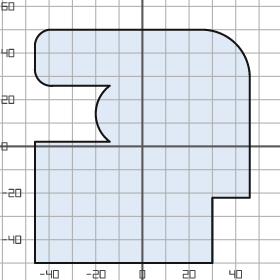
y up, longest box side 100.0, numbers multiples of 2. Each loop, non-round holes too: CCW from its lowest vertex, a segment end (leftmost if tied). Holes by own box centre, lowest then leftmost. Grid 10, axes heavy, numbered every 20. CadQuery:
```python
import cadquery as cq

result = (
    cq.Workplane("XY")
    .moveTo(-46.0, -50.0)
    .lineTo(30.0, -50.0)
    .lineTo(30.0, -22.0)
    .lineTo(46.0, -22.0)
    .lineTo(46.0, 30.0)
    .threePointArc((40.0, 44.0), (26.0, 50.0))
    .lineTo(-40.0, 50.0)
    .threePointArc((-44.0, 48.0), (-46.0, 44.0))
    .lineTo(-46.0, 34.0)
    .threePointArc((-44.0, 28.0), (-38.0, 26.0))
    .lineTo(-14.0, 26.0)
    .threePointArc((-20.0, 14.0), (-14.0, 2.0))
    .lineTo(-46.0, 2.0)
    .close()
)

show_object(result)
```